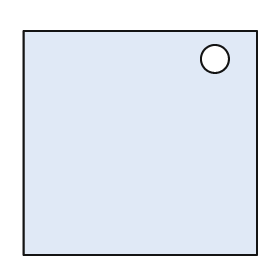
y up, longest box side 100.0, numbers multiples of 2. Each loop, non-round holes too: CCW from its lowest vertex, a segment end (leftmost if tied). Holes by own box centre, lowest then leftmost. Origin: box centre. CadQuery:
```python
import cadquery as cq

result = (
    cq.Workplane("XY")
    .moveTo(-50.0, -48.0)
    .lineTo(50.0, -48.0)
    .lineTo(50.0, 48.0)
    .lineTo(-50.0, 48.0)
    .close()
    .moveTo(32.0, 36.0)
    .circle(6.0)
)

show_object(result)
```